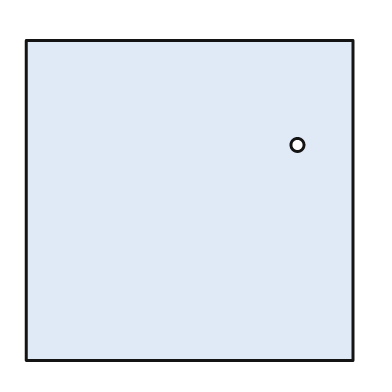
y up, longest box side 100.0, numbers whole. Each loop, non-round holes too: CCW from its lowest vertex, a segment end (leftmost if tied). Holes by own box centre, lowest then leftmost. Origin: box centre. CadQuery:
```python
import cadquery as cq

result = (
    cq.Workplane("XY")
    .moveTo(-50.0, -49.0)
    .lineTo(50.0, -49.0)
    .lineTo(50.0, 49.0)
    .lineTo(-50.0, 49.0)
    .close()
    .moveTo(33.0, 17.0)
    .circle(2.0)
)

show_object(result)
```